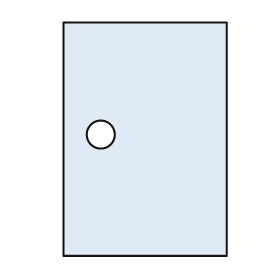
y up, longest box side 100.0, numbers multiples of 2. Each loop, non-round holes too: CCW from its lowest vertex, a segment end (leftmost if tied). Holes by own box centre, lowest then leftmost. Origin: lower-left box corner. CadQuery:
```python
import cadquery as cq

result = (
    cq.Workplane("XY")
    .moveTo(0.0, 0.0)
    .lineTo(70.0, 0.0)
    .lineTo(70.0, 100.0)
    .lineTo(0.0, 100.0)
    .close()
    .moveTo(16.0, 52.0)
    .circle(6.0)
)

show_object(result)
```